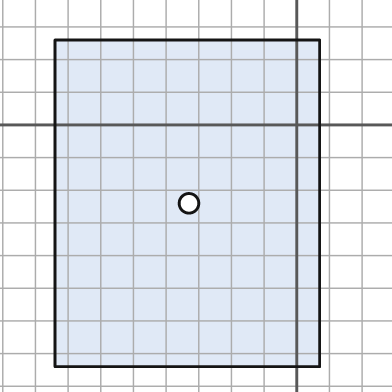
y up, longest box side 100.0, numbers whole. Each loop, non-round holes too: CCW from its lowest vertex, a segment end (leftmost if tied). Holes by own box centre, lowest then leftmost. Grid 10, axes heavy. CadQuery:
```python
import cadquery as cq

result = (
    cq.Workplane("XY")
    .moveTo(-74.0, -74.0)
    .lineTo(7.0, -74.0)
    .lineTo(7.0, 26.0)
    .lineTo(-74.0, 26.0)
    .close()
    .moveTo(-33.0, -24.0)
    .circle(3.0)
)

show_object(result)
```